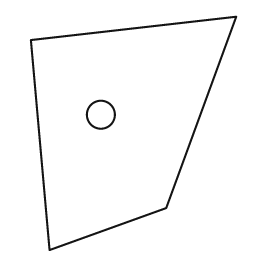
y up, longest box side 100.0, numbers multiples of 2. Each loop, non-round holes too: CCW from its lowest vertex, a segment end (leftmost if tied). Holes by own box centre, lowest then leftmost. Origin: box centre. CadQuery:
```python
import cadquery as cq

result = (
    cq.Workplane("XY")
    .moveTo(-36.0, -50.0)
    .lineTo(14.0, -32.0)
    .lineTo(44.0, 50.0)
    .lineTo(-44.0, 40.0)
    .close()
    .moveTo(-14.0, 8.0)
    .circle(6.0)
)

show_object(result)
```